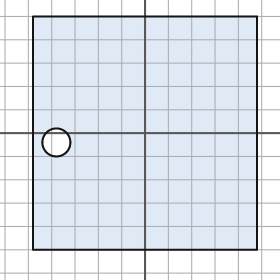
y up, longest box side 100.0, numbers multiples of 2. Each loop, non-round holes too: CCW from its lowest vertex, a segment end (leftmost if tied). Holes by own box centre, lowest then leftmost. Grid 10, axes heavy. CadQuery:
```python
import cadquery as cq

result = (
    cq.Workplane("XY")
    .moveTo(-48.0, -50.0)
    .lineTo(48.0, -50.0)
    .lineTo(48.0, 50.0)
    .lineTo(-48.0, 50.0)
    .close()
    .moveTo(-38.0, -4.0)
    .circle(6.0)
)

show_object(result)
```